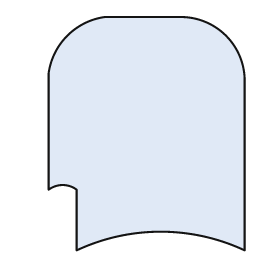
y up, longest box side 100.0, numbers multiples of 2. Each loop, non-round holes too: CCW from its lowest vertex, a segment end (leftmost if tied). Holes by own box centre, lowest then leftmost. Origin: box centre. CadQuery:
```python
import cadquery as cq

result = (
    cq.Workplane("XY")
    .moveTo(-30.0, -50.0)
    .threePointArc((6.0, -42.0), (42.0, -50.0))
    .lineTo(42.0, 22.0)
    .threePointArc((34.0, 42.0), (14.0, 50.0))
    .lineTo(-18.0, 50.0)
    .threePointArc((-34.0, 42.0), (-42.0, 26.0))
    .lineTo(-42.0, -24.0)
    .threePointArc((-36.0, -22.0), (-30.0, -24.0))
    .close()
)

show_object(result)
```